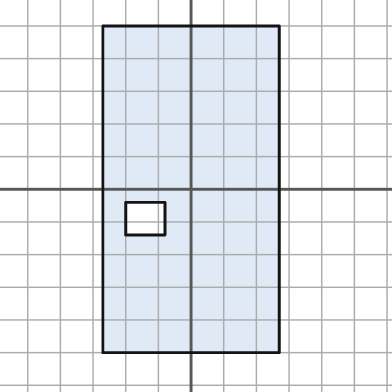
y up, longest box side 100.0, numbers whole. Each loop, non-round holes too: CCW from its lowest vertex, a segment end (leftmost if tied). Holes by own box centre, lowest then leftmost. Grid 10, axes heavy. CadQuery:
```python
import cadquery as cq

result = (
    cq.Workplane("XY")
    .moveTo(-27.0, -50.0)
    .lineTo(27.0, -50.0)
    .lineTo(27.0, 50.0)
    .lineTo(-27.0, 50.0)
    .close()
    .moveTo(-20.0, -14.0)
    .lineTo(-8.0, -14.0)
    .lineTo(-8.0, -4.0)
    .lineTo(-20.0, -4.0)
    .close()
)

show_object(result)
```